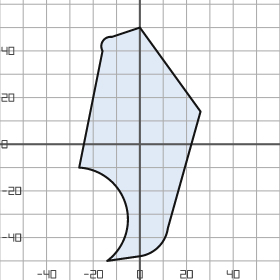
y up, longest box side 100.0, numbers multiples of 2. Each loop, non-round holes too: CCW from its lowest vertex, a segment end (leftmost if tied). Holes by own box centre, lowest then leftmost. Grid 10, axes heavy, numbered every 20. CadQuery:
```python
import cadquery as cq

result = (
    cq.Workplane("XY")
    .moveTo(-14.0, -50.0)
    .lineTo(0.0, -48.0)
    .threePointArc((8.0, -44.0), (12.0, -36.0))
    .lineTo(26.0, 14.0)
    .lineTo(0.0, 50.0)
    .lineTo(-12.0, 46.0)
    .threePointArc((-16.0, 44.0), (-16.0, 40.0))
    .lineTo(-26.0, -10.0)
    .threePointArc((-6.0, -26.0), (-14.0, -50.0))
    .close()
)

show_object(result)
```